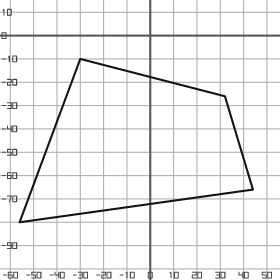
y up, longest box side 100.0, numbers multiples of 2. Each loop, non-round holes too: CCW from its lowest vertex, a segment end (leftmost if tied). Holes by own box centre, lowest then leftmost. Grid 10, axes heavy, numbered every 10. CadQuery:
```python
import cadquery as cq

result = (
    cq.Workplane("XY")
    .moveTo(-56.0, -80.0)
    .lineTo(44.0, -66.0)
    .lineTo(32.0, -26.0)
    .lineTo(-30.0, -10.0)
    .close()
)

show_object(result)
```